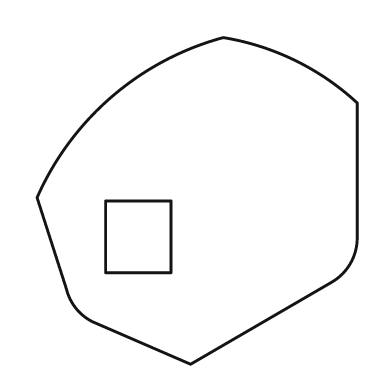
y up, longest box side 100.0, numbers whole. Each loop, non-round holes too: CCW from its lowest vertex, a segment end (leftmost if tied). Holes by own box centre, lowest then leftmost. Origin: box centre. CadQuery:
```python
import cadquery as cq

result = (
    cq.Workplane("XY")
    .moveTo(-2.0, -50.0)
    .lineTo(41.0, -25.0)
    .threePointArc((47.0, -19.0), (49.0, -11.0))
    .lineTo(49.0, 30.0)
    .threePointArc((30.0, 43.0), (8.0, 50.0))
    .threePointArc((-26.0, 32.0), (-49.0, 1.0))
    .lineTo(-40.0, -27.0)
    .threePointArc((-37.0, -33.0), (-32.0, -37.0))
    .close()
    .moveTo(-28.0, -22.0)
    .lineTo(-8.0, -22.0)
    .lineTo(-8.0, 0.0)
    .lineTo(-28.0, 0.0)
    .close()
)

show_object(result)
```